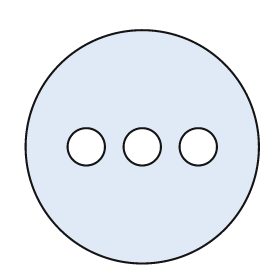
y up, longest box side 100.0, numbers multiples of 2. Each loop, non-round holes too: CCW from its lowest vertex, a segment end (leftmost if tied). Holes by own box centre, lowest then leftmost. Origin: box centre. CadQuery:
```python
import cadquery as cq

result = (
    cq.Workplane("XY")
    .moveTo(0.0, 0.0)
    .circle(50.0)
    .moveTo(-24.0, 0.0)
    .circle(8.0)
    .moveTo(0.0, 0.0)
    .circle(8.0)
    .moveTo(24.0, 0.0)
    .circle(8.0)
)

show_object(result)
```